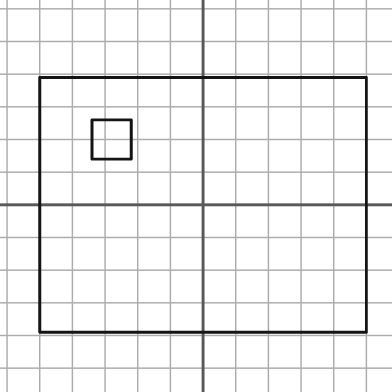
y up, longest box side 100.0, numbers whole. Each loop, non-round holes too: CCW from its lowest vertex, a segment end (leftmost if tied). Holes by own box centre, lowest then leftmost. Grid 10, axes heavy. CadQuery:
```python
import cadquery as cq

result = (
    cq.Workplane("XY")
    .moveTo(-50.0, -39.0)
    .lineTo(50.0, -39.0)
    .lineTo(50.0, 39.0)
    .lineTo(-50.0, 39.0)
    .close()
    .moveTo(-34.0, 14.0)
    .lineTo(-22.0, 14.0)
    .lineTo(-22.0, 26.0)
    .lineTo(-34.0, 26.0)
    .close()
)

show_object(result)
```